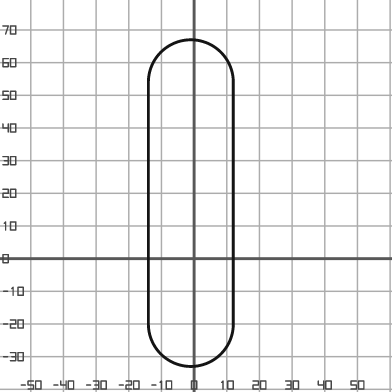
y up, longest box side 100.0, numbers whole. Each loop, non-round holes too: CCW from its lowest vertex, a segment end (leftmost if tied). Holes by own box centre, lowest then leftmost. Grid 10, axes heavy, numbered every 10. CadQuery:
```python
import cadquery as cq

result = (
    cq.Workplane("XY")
    .moveTo(-14.0, -20.0)
    .threePointArc((-1.0, -33.0), (12.0, -20.0))
    .lineTo(12.0, 54.0)
    .threePointArc((-1.0, 67.0), (-14.0, 54.0))
    .close()
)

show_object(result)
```